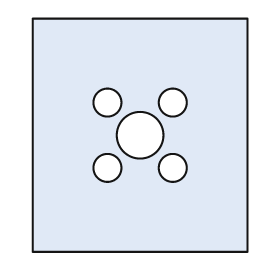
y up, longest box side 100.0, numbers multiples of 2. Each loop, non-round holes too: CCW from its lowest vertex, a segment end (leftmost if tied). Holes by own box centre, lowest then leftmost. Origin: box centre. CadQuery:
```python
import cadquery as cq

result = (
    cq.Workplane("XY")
    .moveTo(-46.0, -50.0)
    .lineTo(46.0, -50.0)
    .lineTo(46.0, 50.0)
    .lineTo(-46.0, 50.0)
    .close()
    .moveTo(-14.0, -14.0)
    .circle(6.0)
    .moveTo(14.0, -14.0)
    .circle(6.0)
    .moveTo(0.0, 0.0)
    .circle(10.0)
    .moveTo(-14.0, 14.0)
    .circle(6.0)
    .moveTo(14.0, 14.0)
    .circle(6.0)
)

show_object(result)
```